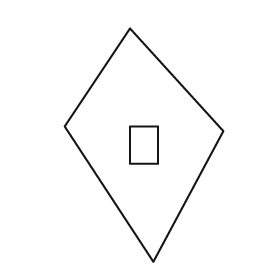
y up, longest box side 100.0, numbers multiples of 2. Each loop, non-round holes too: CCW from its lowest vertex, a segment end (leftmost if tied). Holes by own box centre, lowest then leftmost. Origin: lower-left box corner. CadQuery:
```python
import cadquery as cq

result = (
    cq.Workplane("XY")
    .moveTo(38.0, 0.0)
    .lineTo(68.0, 56.0)
    .lineTo(28.0, 100.0)
    .lineTo(0.0, 58.0)
    .close()
    .moveTo(28.0, 42.0)
    .lineTo(40.0, 42.0)
    .lineTo(40.0, 58.0)
    .lineTo(28.0, 58.0)
    .close()
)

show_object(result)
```